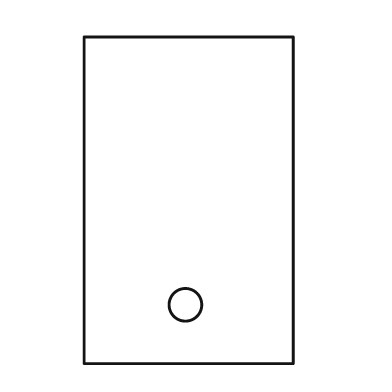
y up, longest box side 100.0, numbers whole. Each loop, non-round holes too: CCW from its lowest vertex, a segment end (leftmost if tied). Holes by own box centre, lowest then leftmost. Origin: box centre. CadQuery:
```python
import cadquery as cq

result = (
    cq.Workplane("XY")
    .moveTo(-32.0, -50.0)
    .lineTo(32.0, -50.0)
    .lineTo(32.0, 50.0)
    .lineTo(-32.0, 50.0)
    .close()
    .moveTo(-1.0, -32.0)
    .circle(5.0)
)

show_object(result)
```